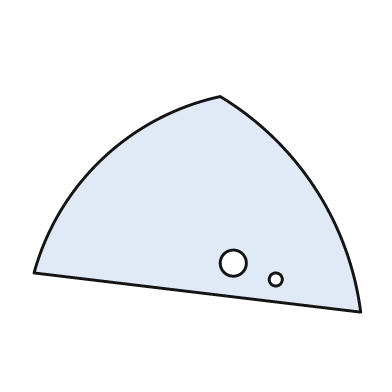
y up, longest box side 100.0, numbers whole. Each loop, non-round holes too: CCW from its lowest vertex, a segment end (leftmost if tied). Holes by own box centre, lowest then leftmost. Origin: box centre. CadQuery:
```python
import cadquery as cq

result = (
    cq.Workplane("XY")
    .moveTo(50.0, -33.0)
    .threePointArc((36.0, 5.0), (7.0, 33.0))
    .threePointArc((-29.0, 14.0), (-50.0, -21.0))
    .close()
    .moveTo(24.0, -23.0)
    .circle(2.0)
    .moveTo(11.0, -18.0)
    .circle(4.0)
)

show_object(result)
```